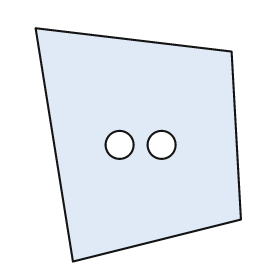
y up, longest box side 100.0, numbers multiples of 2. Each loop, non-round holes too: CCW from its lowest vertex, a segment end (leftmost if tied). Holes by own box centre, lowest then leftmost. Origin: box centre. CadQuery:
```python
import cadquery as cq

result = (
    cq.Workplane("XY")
    .moveTo(-28.0, -50.0)
    .lineTo(44.0, -32.0)
    .lineTo(40.0, 40.0)
    .lineTo(-44.0, 50.0)
    .close()
    .moveTo(-8.0, 0.0)
    .circle(6.0)
    .moveTo(10.0, 0.0)
    .circle(6.0)
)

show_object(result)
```